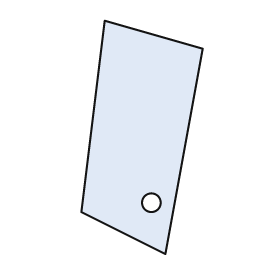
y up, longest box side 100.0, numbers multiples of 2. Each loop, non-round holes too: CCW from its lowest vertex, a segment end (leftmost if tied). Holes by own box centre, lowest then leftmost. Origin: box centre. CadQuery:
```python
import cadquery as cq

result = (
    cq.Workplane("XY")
    .moveTo(10.0, -50.0)
    .lineTo(26.0, 38.0)
    .lineTo(-16.0, 50.0)
    .lineTo(-26.0, -32.0)
    .close()
    .moveTo(4.0, -28.0)
    .circle(4.0)
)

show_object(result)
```